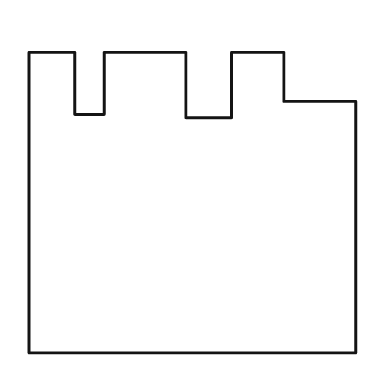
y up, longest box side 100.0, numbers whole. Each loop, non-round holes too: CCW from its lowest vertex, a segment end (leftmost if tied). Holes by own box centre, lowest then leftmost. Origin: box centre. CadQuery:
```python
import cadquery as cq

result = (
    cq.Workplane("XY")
    .moveTo(-50.0, -46.0)
    .lineTo(50.0, -46.0)
    .lineTo(50.0, 31.0)
    .lineTo(28.0, 31.0)
    .lineTo(28.0, 46.0)
    .lineTo(12.0, 46.0)
    .lineTo(12.0, 26.0)
    .lineTo(-2.0, 26.0)
    .lineTo(-2.0, 46.0)
    .lineTo(-27.0, 46.0)
    .lineTo(-27.0, 27.0)
    .lineTo(-36.0, 27.0)
    .lineTo(-36.0, 46.0)
    .lineTo(-50.0, 46.0)
    .close()
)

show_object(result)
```